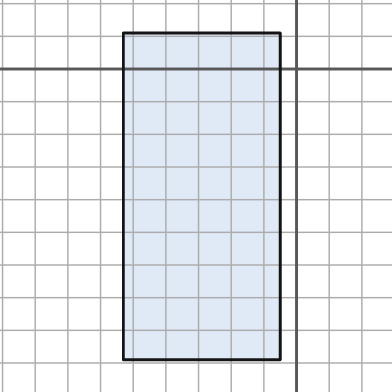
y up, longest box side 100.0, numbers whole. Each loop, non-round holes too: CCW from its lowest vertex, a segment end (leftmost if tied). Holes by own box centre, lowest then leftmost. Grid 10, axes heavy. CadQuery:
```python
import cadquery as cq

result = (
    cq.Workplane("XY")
    .moveTo(-53.0, -89.0)
    .lineTo(-5.0, -89.0)
    .lineTo(-5.0, 11.0)
    .lineTo(-53.0, 11.0)
    .close()
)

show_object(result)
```